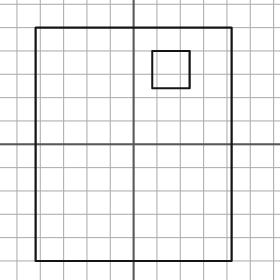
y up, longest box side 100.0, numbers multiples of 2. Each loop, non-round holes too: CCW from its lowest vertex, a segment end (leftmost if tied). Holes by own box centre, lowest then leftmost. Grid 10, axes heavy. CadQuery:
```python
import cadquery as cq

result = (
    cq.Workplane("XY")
    .moveTo(-42.0, -50.0)
    .lineTo(42.0, -50.0)
    .lineTo(42.0, 50.0)
    .lineTo(-42.0, 50.0)
    .close()
    .moveTo(8.0, 24.0)
    .lineTo(24.0, 24.0)
    .lineTo(24.0, 40.0)
    .lineTo(8.0, 40.0)
    .close()
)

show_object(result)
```